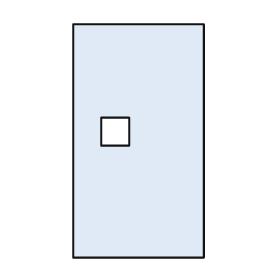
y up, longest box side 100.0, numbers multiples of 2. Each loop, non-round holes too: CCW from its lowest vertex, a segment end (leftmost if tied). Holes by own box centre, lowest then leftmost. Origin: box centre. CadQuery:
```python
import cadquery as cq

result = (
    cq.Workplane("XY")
    .moveTo(-28.0, -50.0)
    .lineTo(28.0, -50.0)
    .lineTo(28.0, 50.0)
    .lineTo(-28.0, 50.0)
    .close()
    .moveTo(-16.0, -2.0)
    .lineTo(-4.0, -2.0)
    .lineTo(-4.0, 10.0)
    .lineTo(-16.0, 10.0)
    .close()
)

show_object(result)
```